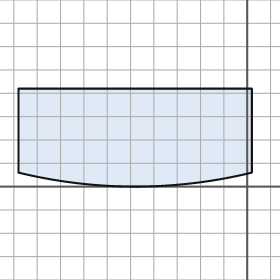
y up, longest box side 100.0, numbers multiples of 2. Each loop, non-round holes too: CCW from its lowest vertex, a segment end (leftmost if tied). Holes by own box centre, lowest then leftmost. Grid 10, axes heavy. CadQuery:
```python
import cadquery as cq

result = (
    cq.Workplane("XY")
    .moveTo(-98.0, 6.0)
    .threePointArc((-48.0, 0.0), (2.0, 6.0))
    .lineTo(2.0, 42.0)
    .lineTo(-98.0, 42.0)
    .close()
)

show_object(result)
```